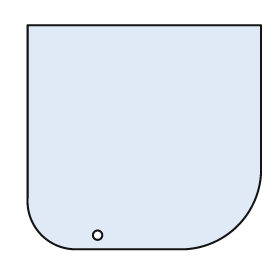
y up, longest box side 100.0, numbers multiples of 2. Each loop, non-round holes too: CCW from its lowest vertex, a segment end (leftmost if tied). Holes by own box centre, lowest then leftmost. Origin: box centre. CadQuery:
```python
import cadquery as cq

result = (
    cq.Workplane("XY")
    .moveTo(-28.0, -48.0)
    .lineTo(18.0, -48.0)
    .threePointArc((40.0, -38.0), (50.0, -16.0))
    .lineTo(50.0, 48.0)
    .lineTo(-50.0, 48.0)
    .lineTo(-50.0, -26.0)
    .threePointArc((-44.0, -42.0), (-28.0, -48.0))
    .close()
    .moveTo(-20.0, -42.0)
    .circle(2.0)
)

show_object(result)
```